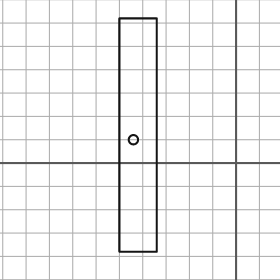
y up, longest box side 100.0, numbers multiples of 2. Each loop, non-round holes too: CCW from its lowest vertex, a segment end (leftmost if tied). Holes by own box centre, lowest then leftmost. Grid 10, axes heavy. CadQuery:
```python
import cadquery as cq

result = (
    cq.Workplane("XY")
    .moveTo(-50.0, -38.0)
    .lineTo(-34.0, -38.0)
    .lineTo(-34.0, 62.0)
    .lineTo(-50.0, 62.0)
    .close()
    .moveTo(-44.0, 10.0)
    .circle(2.0)
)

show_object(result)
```